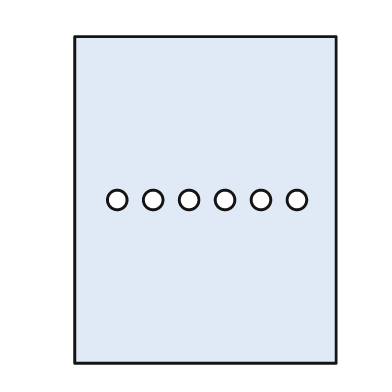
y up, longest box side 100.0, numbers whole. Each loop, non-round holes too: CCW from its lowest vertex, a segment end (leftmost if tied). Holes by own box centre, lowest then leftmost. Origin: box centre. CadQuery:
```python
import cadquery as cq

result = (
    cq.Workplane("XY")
    .moveTo(-40.0, -50.0)
    .lineTo(40.0, -50.0)
    .lineTo(40.0, 50.0)
    .lineTo(-40.0, 50.0)
    .close()
    .moveTo(-27.0, 0.0)
    .circle(3.0)
    .moveTo(-16.0, 0.0)
    .circle(3.0)
    .moveTo(-5.0, 0.0)
    .circle(3.0)
    .moveTo(6.0, 0.0)
    .circle(3.0)
    .moveTo(17.0, 0.0)
    .circle(3.0)
    .moveTo(28.0, 0.0)
    .circle(3.0)
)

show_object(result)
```